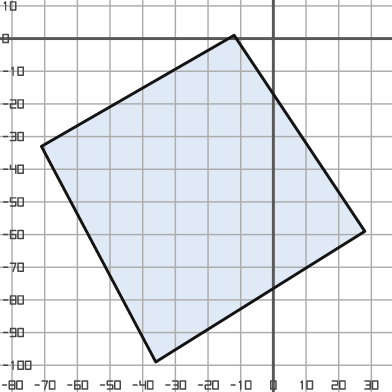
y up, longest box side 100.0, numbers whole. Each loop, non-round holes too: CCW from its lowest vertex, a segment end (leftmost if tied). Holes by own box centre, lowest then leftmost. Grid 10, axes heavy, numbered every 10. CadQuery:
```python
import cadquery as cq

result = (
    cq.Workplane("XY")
    .moveTo(-36.0, -99.0)
    .lineTo(28.0, -59.0)
    .lineTo(-12.0, 1.0)
    .lineTo(-71.0, -33.0)
    .close()
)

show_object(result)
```